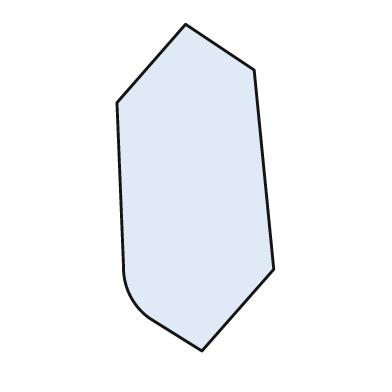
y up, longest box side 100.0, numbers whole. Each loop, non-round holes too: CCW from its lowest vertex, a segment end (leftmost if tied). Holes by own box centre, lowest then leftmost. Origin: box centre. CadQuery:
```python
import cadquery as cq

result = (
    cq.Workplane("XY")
    .moveTo(2.0, -50.0)
    .lineTo(24.0, -25.0)
    .lineTo(18.0, 36.0)
    .lineTo(-3.0, 50.0)
    .lineTo(-24.0, 26.0)
    .lineTo(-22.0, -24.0)
    .threePointArc((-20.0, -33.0), (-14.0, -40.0))
    .close()
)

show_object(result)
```